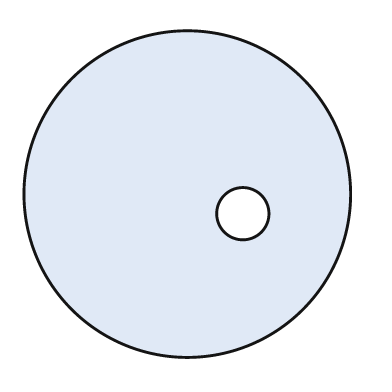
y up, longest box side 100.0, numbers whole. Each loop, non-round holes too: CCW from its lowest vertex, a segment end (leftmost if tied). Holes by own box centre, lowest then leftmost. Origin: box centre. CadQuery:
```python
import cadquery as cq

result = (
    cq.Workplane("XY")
    .moveTo(0.0, 0.0)
    .circle(50.0)
    .moveTo(17.0, -6.0)
    .circle(8.0)
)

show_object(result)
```